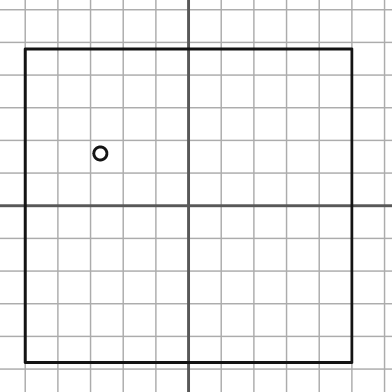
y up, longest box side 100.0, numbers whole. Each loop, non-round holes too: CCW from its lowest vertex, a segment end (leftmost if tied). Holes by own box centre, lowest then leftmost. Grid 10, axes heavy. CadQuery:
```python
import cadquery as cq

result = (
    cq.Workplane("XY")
    .moveTo(-50.0, -48.0)
    .lineTo(50.0, -48.0)
    .lineTo(50.0, 48.0)
    .lineTo(-50.0, 48.0)
    .close()
    .moveTo(-27.0, 16.0)
    .circle(2.0)
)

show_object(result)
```